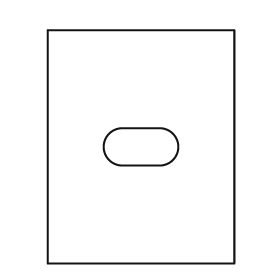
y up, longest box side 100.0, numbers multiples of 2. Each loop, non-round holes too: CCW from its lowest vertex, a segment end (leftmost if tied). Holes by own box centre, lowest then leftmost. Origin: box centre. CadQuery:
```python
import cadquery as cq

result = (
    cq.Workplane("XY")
    .moveTo(-40.0, -50.0)
    .lineTo(40.0, -50.0)
    .lineTo(40.0, 50.0)
    .lineTo(-40.0, 50.0)
    .close()
    .moveTo(-8.0, -8.0)
    .lineTo(8.0, -8.0)
    .threePointArc((16.0, 0.0), (8.0, 8.0))
    .lineTo(-8.0, 8.0)
    .threePointArc((-16.0, 0.0), (-8.0, -8.0))
    .close()
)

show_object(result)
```